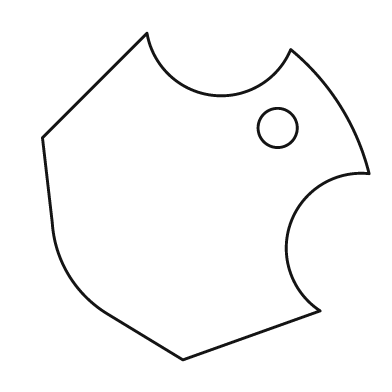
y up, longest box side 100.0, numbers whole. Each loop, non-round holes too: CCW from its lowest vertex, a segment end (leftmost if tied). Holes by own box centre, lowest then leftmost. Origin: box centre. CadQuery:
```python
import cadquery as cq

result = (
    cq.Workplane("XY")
    .moveTo(-7.0, -50.0)
    .lineTo(35.0, -35.0)
    .threePointArc((26.0, -8.0), (50.0, 7.0))
    .threePointArc((41.0, 28.0), (26.0, 45.0))
    .threePointArc((2.0, 31.0), (-18.0, 50.0))
    .lineTo(-50.0, 18.0)
    .lineTo(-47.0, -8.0)
    .threePointArc((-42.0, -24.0), (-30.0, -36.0))
    .close()
    .moveTo(22.0, 21.0)
    .circle(6.0)
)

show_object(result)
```